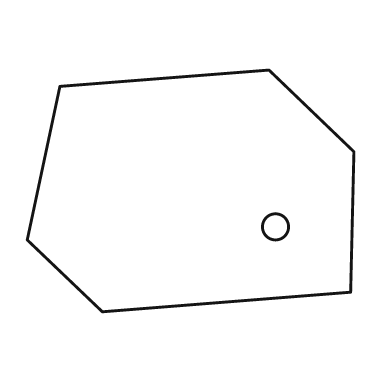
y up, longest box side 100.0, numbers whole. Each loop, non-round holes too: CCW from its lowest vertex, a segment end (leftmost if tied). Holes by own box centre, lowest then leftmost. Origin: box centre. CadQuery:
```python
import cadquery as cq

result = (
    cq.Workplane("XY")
    .moveTo(-27.0, -37.0)
    .lineTo(49.0, -31.0)
    .lineTo(50.0, 12.0)
    .lineTo(24.0, 37.0)
    .lineTo(-40.0, 32.0)
    .lineTo(-50.0, -15.0)
    .close()
    .moveTo(26.0, -11.0)
    .circle(4.0)
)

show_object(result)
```